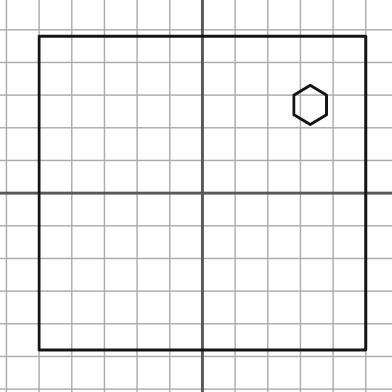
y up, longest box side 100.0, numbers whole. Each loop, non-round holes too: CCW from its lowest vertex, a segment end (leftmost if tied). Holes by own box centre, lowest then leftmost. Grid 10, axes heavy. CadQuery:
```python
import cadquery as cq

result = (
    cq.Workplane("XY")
    .moveTo(-50.0, -48.0)
    .lineTo(50.0, -48.0)
    .lineTo(50.0, 48.0)
    .lineTo(-50.0, 48.0)
    .close()
    .moveTo(33.0, 21.0)
    .lineTo(38.0, 24.0)
    .lineTo(38.0, 30.0)
    .lineTo(33.0, 33.0)
    .lineTo(28.0, 30.0)
    .lineTo(28.0, 24.0)
    .close()
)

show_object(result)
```